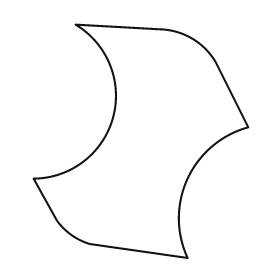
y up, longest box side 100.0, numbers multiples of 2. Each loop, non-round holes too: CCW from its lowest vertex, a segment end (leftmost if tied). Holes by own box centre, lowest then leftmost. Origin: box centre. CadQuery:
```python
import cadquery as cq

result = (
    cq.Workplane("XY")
    .moveTo(20.0, -50.0)
    .threePointArc((20.0, -16.0), (46.0, 6.0))
    .lineTo(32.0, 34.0)
    .threePointArc((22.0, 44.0), (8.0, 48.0))
    .lineTo(-28.0, 50.0)
    .threePointArc((-12.0, 10.0), (-46.0, -16.0))
    .lineTo(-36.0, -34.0)
    .threePointArc((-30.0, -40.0), (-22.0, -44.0))
    .close()
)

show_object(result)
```